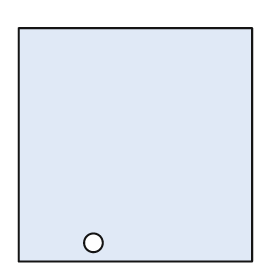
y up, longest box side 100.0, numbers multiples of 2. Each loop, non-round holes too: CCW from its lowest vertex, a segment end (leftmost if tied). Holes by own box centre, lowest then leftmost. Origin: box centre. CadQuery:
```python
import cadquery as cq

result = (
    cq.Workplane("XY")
    .moveTo(-50.0, -50.0)
    .lineTo(50.0, -50.0)
    .lineTo(50.0, 50.0)
    .lineTo(-50.0, 50.0)
    .close()
    .moveTo(-18.0, -42.0)
    .circle(4.0)
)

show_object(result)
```